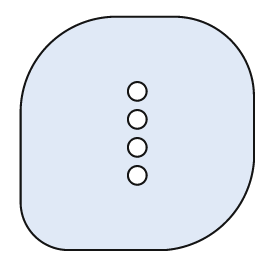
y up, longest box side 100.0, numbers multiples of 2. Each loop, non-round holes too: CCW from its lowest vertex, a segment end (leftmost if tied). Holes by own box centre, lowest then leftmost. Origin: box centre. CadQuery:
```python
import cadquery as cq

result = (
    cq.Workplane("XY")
    .moveTo(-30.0, -50.0)
    .lineTo(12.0, -50.0)
    .threePointArc((38.0, -38.0), (50.0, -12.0))
    .lineTo(50.0, 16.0)
    .threePointArc((40.0, 40.0), (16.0, 50.0))
    .lineTo(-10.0, 50.0)
    .threePointArc((-38.0, 38.0), (-50.0, 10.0))
    .lineTo(-50.0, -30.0)
    .threePointArc((-44.0, -44.0), (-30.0, -50.0))
    .close()
    .moveTo(0.0, -18.0)
    .circle(4.0)
    .moveTo(0.0, -6.0)
    .circle(4.0)
    .moveTo(0.0, 6.0)
    .circle(4.0)
    .moveTo(0.0, 18.0)
    .circle(4.0)
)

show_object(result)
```